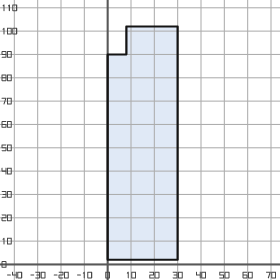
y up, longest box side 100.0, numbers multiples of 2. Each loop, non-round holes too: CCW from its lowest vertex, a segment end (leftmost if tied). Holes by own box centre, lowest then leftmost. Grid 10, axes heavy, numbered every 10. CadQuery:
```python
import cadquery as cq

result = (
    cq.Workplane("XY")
    .moveTo(0.0, 2.0)
    .lineTo(30.0, 2.0)
    .lineTo(30.0, 102.0)
    .lineTo(8.0, 102.0)
    .lineTo(8.0, 90.0)
    .lineTo(0.0, 90.0)
    .close()
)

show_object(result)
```